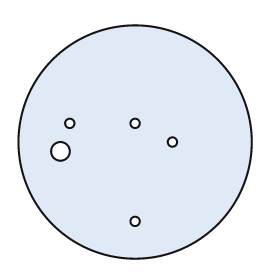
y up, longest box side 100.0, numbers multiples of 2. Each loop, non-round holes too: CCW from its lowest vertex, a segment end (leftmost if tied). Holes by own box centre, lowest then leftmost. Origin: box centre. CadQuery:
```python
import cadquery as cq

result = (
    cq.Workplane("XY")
    .moveTo(0.0, 0.0)
    .circle(50.0)
    .moveTo(0.0, -34.0)
    .circle(2.0)
    .moveTo(-32.0, -4.0)
    .circle(4.0)
    .moveTo(16.0, 0.0)
    .circle(2.0)
    .moveTo(-28.0, 8.0)
    .circle(2.0)
    .moveTo(0.0, 8.0)
    .circle(2.0)
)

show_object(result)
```